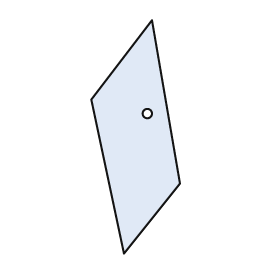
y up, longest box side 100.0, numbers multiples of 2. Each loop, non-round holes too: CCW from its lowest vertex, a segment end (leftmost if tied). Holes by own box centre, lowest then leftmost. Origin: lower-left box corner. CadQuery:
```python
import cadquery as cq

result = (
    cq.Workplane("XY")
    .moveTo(14.0, 0.0)
    .lineTo(38.0, 30.0)
    .lineTo(26.0, 100.0)
    .lineTo(0.0, 66.0)
    .close()
    .moveTo(24.0, 60.0)
    .circle(2.0)
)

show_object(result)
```